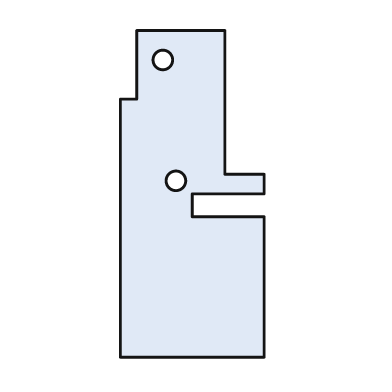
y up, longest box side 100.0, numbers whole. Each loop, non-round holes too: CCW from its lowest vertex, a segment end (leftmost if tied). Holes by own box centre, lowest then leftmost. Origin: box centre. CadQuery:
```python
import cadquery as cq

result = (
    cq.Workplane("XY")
    .moveTo(-22.0, -50.0)
    .lineTo(22.0, -50.0)
    .lineTo(22.0, -7.0)
    .lineTo(0.0, -7.0)
    .lineTo(0.0, 0.0)
    .lineTo(22.0, 0.0)
    .lineTo(22.0, 6.0)
    .lineTo(10.0, 6.0)
    .lineTo(10.0, 50.0)
    .lineTo(-17.0, 50.0)
    .lineTo(-17.0, 29.0)
    .lineTo(-22.0, 29.0)
    .close()
    .moveTo(-5.0, 4.0)
    .circle(3.0)
    .moveTo(-9.0, 41.0)
    .circle(3.0)
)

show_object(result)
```